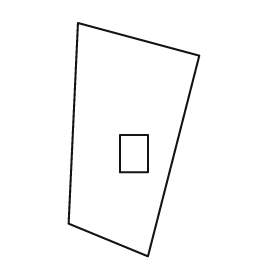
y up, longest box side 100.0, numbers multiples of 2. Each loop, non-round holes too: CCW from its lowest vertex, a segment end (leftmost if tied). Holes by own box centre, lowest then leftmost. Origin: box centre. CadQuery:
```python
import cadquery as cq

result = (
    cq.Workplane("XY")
    .moveTo(6.0, -50.0)
    .lineTo(28.0, 36.0)
    .lineTo(-24.0, 50.0)
    .lineTo(-28.0, -36.0)
    .close()
    .moveTo(-6.0, -14.0)
    .lineTo(6.0, -14.0)
    .lineTo(6.0, 2.0)
    .lineTo(-6.0, 2.0)
    .close()
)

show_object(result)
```